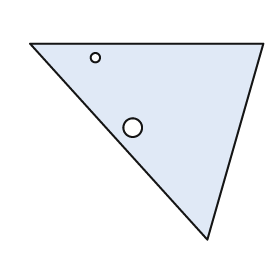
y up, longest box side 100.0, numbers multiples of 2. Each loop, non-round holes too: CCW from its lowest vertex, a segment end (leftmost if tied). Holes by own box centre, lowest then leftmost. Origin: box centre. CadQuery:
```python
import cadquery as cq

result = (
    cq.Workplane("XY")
    .moveTo(26.0, -42.0)
    .lineTo(50.0, 42.0)
    .lineTo(-50.0, 42.0)
    .close()
    .moveTo(-6.0, 6.0)
    .circle(4.0)
    .moveTo(-22.0, 36.0)
    .circle(2.0)
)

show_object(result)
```